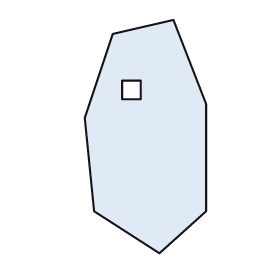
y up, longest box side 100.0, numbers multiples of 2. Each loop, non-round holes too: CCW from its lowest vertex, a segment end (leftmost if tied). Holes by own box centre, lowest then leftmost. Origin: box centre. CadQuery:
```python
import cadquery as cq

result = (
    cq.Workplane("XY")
    .moveTo(6.0, -50.0)
    .lineTo(26.0, -32.0)
    .lineTo(26.0, 14.0)
    .lineTo(12.0, 50.0)
    .lineTo(-14.0, 44.0)
    .lineTo(-26.0, 8.0)
    .lineTo(-22.0, -32.0)
    .close()
    .moveTo(-10.0, 16.0)
    .lineTo(-2.0, 16.0)
    .lineTo(-2.0, 24.0)
    .lineTo(-10.0, 24.0)
    .close()
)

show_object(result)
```